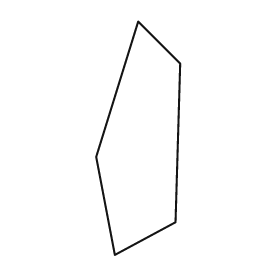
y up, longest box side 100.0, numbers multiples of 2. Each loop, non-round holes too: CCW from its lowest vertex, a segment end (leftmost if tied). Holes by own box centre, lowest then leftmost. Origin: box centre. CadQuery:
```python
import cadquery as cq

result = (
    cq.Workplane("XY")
    .moveTo(-10.0, -50.0)
    .lineTo(16.0, -36.0)
    .lineTo(18.0, 32.0)
    .lineTo(0.0, 50.0)
    .lineTo(-18.0, -8.0)
    .close()
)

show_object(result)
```